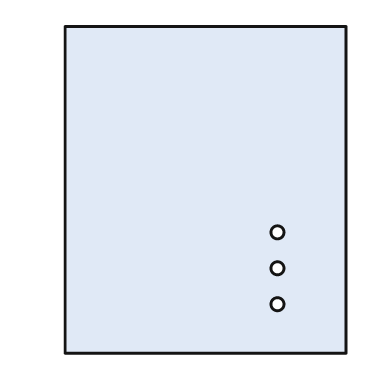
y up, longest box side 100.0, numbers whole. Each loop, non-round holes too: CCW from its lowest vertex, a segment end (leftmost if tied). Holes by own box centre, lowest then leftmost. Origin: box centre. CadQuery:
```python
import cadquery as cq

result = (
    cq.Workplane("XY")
    .moveTo(-43.0, -50.0)
    .lineTo(43.0, -50.0)
    .lineTo(43.0, 50.0)
    .lineTo(-43.0, 50.0)
    .close()
    .moveTo(22.0, -35.0)
    .circle(2.0)
    .moveTo(22.0, -24.0)
    .circle(2.0)
    .moveTo(22.0, -13.0)
    .circle(2.0)
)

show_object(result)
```